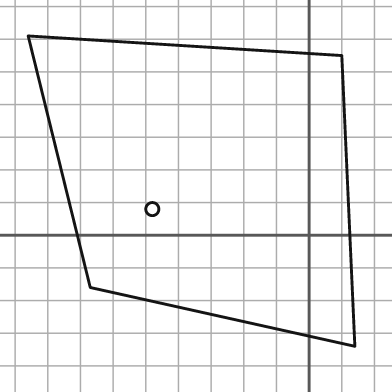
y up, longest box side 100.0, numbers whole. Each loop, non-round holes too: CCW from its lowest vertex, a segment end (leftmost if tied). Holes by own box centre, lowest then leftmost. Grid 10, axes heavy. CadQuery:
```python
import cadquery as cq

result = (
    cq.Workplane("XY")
    .moveTo(14.0, -34.0)
    .lineTo(10.0, 55.0)
    .lineTo(-86.0, 61.0)
    .lineTo(-67.0, -16.0)
    .close()
    .moveTo(-48.0, 8.0)
    .circle(2.0)
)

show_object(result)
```